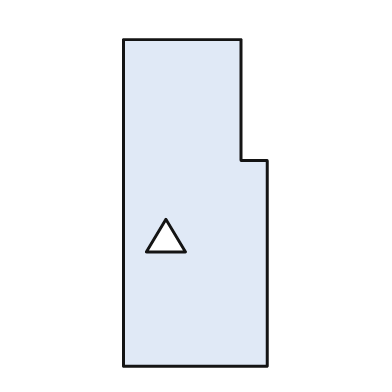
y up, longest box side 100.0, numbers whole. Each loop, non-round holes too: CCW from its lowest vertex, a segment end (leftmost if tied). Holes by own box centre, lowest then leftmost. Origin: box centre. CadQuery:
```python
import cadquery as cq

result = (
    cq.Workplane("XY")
    .moveTo(-22.0, -50.0)
    .lineTo(22.0, -50.0)
    .lineTo(22.0, 13.0)
    .lineTo(14.0, 13.0)
    .lineTo(14.0, 50.0)
    .lineTo(-22.0, 50.0)
    .close()
    .moveTo(-15.0, -15.0)
    .lineTo(-3.0, -15.0)
    .lineTo(-9.0, -5.0)
    .close()
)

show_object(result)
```